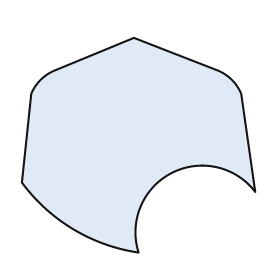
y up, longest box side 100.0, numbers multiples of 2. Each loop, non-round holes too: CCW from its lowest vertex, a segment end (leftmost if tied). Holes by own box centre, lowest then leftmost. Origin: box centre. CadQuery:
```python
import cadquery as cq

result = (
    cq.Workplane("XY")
    .moveTo(0.0, -46.0)
    .threePointArc((14.0, -12.0), (50.0, -20.0))
    .lineTo(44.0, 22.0)
    .threePointArc((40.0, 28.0), (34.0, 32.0))
    .lineTo(-2.0, 46.0)
    .lineTo(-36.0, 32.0)
    .threePointArc((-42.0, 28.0), (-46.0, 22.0))
    .lineTo(-50.0, -16.0)
    .threePointArc((-28.0, -36.0), (0.0, -46.0))
    .close()
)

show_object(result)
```